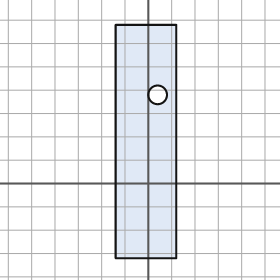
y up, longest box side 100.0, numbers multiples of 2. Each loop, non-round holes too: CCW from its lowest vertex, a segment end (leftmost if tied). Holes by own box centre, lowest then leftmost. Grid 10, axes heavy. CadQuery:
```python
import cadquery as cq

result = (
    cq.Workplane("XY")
    .moveTo(-14.0, -32.0)
    .lineTo(12.0, -32.0)
    .lineTo(12.0, 68.0)
    .lineTo(-14.0, 68.0)
    .close()
    .moveTo(4.0, 38.0)
    .circle(4.0)
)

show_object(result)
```